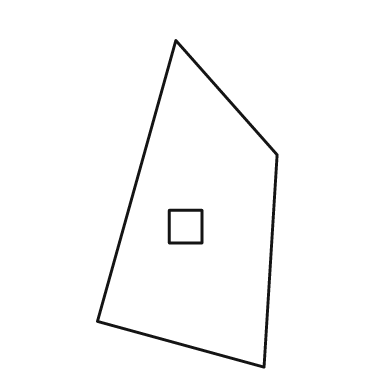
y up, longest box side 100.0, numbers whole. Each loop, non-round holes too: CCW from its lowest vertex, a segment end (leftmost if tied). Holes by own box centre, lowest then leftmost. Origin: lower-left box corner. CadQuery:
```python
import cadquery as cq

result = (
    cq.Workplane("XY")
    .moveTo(51.0, 0.0)
    .lineTo(55.0, 65.0)
    .lineTo(24.0, 100.0)
    .lineTo(0.0, 14.0)
    .close()
    .moveTo(22.0, 38.0)
    .lineTo(32.0, 38.0)
    .lineTo(32.0, 48.0)
    .lineTo(22.0, 48.0)
    .close()
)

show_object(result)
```